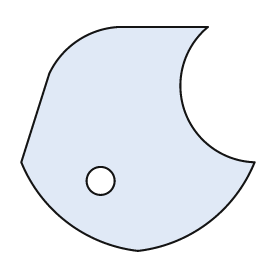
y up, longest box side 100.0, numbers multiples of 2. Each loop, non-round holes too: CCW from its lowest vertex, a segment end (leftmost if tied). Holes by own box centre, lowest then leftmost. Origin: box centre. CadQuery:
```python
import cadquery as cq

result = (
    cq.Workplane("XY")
    .moveTo(0.0, -48.0)
    .threePointArc((30.0, -36.0), (50.0, -10.0))
    .threePointArc((20.0, 12.0), (30.0, 48.0))
    .lineTo(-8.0, 48.0)
    .threePointArc((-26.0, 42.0), (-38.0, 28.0))
    .lineTo(-50.0, -10.0)
    .threePointArc((-30.0, -36.0), (0.0, -48.0))
    .close()
    .moveTo(-16.0, -18.0)
    .circle(6.0)
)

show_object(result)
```